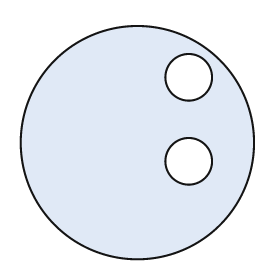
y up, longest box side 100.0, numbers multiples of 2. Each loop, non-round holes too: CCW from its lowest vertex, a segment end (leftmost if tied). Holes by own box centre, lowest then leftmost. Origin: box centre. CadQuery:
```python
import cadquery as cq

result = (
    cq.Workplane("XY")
    .moveTo(0.0, 0.0)
    .circle(50.0)
    .moveTo(22.0, -8.0)
    .circle(10.0)
    .moveTo(22.0, 28.0)
    .circle(10.0)
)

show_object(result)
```